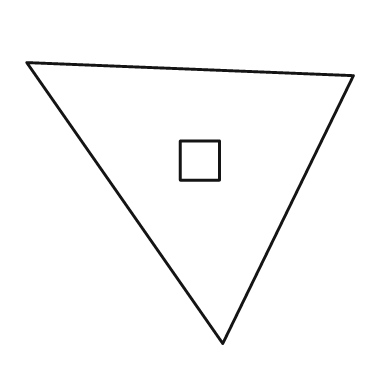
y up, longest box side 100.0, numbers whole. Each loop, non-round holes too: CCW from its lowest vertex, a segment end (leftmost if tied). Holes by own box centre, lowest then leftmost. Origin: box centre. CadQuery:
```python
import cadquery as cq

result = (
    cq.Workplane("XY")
    .moveTo(10.0, -43.0)
    .lineTo(50.0, 39.0)
    .lineTo(-50.0, 43.0)
    .close()
    .moveTo(-3.0, 7.0)
    .lineTo(9.0, 7.0)
    .lineTo(9.0, 19.0)
    .lineTo(-3.0, 19.0)
    .close()
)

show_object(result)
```